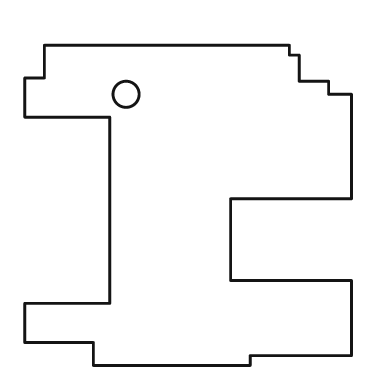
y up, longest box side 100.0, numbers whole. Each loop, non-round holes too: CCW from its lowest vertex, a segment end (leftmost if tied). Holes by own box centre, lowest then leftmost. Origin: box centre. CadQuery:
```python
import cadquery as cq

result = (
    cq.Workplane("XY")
    .moveTo(-29.0, -49.0)
    .lineTo(19.0, -49.0)
    .lineTo(19.0, -46.0)
    .lineTo(50.0, -46.0)
    .lineTo(50.0, -23.0)
    .lineTo(13.0, -23.0)
    .lineTo(13.0, 2.0)
    .lineTo(50.0, 2.0)
    .lineTo(50.0, 34.0)
    .lineTo(43.0, 34.0)
    .lineTo(43.0, 38.0)
    .lineTo(34.0, 38.0)
    .lineTo(34.0, 46.0)
    .lineTo(31.0, 46.0)
    .lineTo(31.0, 49.0)
    .lineTo(-44.0, 49.0)
    .lineTo(-44.0, 39.0)
    .lineTo(-50.0, 39.0)
    .lineTo(-50.0, 27.0)
    .lineTo(-24.0, 27.0)
    .lineTo(-24.0, -30.0)
    .lineTo(-50.0, -30.0)
    .lineTo(-50.0, -42.0)
    .lineTo(-29.0, -42.0)
    .close()
    .moveTo(-19.0, 34.0)
    .circle(4.0)
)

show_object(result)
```